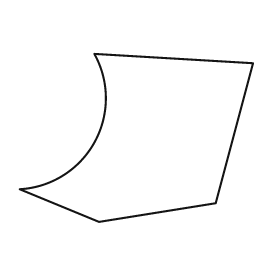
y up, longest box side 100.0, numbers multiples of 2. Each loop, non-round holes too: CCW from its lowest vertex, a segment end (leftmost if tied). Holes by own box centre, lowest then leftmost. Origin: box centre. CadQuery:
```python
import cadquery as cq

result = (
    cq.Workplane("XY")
    .moveTo(-16.0, -36.0)
    .lineTo(34.0, -28.0)
    .lineTo(50.0, 32.0)
    .lineTo(-18.0, 36.0)
    .threePointArc((-18.0, -2.0), (-50.0, -22.0))
    .close()
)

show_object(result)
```